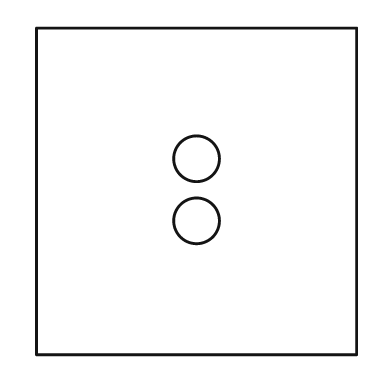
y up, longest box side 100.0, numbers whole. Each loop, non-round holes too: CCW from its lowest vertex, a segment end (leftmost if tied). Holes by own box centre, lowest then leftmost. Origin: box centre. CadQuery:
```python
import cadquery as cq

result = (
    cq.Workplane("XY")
    .moveTo(-49.0, -50.0)
    .lineTo(49.0, -50.0)
    .lineTo(49.0, 50.0)
    .lineTo(-49.0, 50.0)
    .close()
    .moveTo(0.0, -9.0)
    .circle(7.0)
    .moveTo(0.0, 10.0)
    .circle(7.0)
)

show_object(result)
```